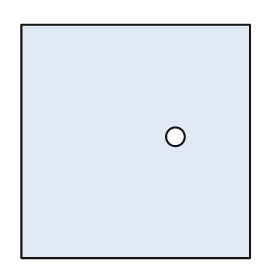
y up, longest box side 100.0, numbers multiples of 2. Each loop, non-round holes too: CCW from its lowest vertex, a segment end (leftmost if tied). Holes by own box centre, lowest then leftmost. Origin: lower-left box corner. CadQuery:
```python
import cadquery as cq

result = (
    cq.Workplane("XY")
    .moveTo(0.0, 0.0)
    .lineTo(98.0, 0.0)
    .lineTo(98.0, 100.0)
    .lineTo(0.0, 100.0)
    .close()
    .moveTo(66.0, 52.0)
    .circle(4.0)
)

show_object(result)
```